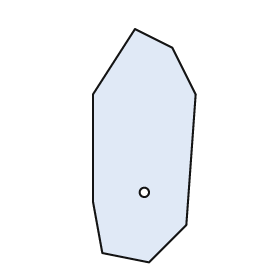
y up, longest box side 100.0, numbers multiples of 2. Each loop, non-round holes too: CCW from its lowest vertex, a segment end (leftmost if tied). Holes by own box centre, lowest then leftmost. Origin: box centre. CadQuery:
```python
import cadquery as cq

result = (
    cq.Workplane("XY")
    .moveTo(2.0, -50.0)
    .lineTo(18.0, -34.0)
    .lineTo(22.0, 22.0)
    .lineTo(12.0, 42.0)
    .lineTo(-4.0, 50.0)
    .lineTo(-22.0, 22.0)
    .lineTo(-22.0, -24.0)
    .lineTo(-18.0, -46.0)
    .close()
    .moveTo(0.0, -20.0)
    .circle(2.0)
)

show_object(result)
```